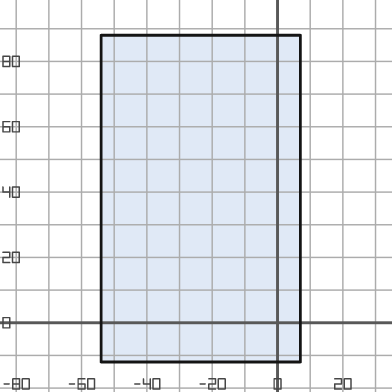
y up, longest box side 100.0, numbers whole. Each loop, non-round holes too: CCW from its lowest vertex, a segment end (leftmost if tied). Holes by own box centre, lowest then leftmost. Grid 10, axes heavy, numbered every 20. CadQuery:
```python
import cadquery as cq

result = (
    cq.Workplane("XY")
    .moveTo(-54.0, -12.0)
    .lineTo(7.0, -12.0)
    .lineTo(7.0, 88.0)
    .lineTo(-54.0, 88.0)
    .close()
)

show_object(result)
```